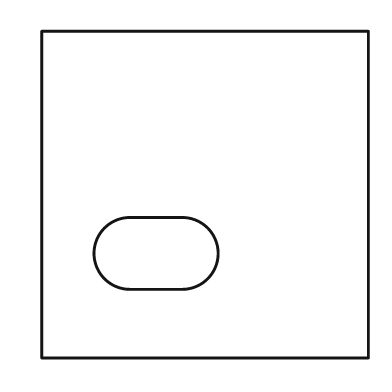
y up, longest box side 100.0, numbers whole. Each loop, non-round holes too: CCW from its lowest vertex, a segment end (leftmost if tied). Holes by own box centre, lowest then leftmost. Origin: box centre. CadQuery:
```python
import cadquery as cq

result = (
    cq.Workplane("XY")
    .moveTo(-50.0, -50.0)
    .lineTo(50.0, -50.0)
    .lineTo(50.0, 50.0)
    .lineTo(-50.0, 50.0)
    .close()
    .moveTo(-23.0, -29.0)
    .lineTo(-7.0, -29.0)
    .threePointArc((4.0, -18.0), (-7.0, -7.0))
    .lineTo(-23.0, -7.0)
    .threePointArc((-34.0, -18.0), (-23.0, -29.0))
    .close()
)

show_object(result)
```